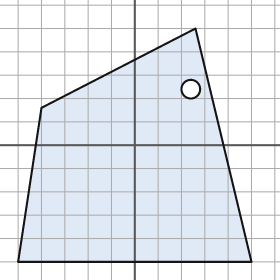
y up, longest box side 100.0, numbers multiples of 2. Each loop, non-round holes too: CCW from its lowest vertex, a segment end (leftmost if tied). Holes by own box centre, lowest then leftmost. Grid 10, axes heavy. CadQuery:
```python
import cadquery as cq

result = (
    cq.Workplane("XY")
    .moveTo(-50.0, -50.0)
    .lineTo(50.0, -50.0)
    .lineTo(26.0, 50.0)
    .lineTo(-40.0, 16.0)
    .close()
    .moveTo(24.0, 24.0)
    .circle(4.0)
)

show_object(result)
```